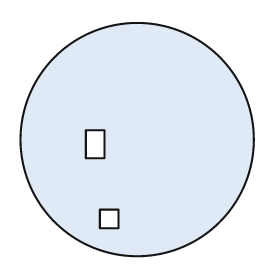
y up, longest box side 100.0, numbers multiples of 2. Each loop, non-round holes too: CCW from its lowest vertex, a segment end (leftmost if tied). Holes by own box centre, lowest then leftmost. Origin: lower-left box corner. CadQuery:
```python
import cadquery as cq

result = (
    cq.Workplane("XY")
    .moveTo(50.0, 50.0)
    .circle(50.0)
    .moveTo(34.0, 12.0)
    .lineTo(42.0, 12.0)
    .lineTo(42.0, 20.0)
    .lineTo(34.0, 20.0)
    .close()
    .moveTo(28.0, 42.0)
    .lineTo(36.0, 42.0)
    .lineTo(36.0, 54.0)
    .lineTo(28.0, 54.0)
    .close()
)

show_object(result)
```